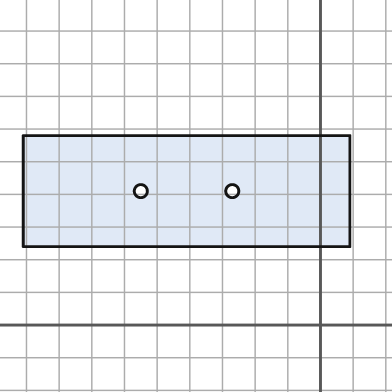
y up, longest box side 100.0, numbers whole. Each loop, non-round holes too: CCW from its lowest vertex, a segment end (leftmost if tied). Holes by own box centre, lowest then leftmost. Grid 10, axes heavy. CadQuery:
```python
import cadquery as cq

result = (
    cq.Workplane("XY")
    .moveTo(-91.0, 24.0)
    .lineTo(9.0, 24.0)
    .lineTo(9.0, 58.0)
    .lineTo(-91.0, 58.0)
    .close()
    .moveTo(-55.0, 41.0)
    .circle(2.0)
    .moveTo(-27.0, 41.0)
    .circle(2.0)
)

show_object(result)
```